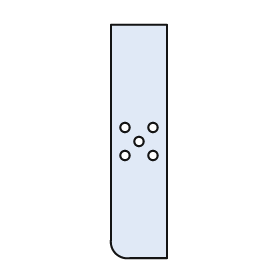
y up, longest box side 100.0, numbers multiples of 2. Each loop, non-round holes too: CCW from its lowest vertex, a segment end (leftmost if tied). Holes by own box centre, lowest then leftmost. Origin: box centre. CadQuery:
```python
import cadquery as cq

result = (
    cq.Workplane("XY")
    .moveTo(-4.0, -50.0)
    .lineTo(12.0, -50.0)
    .lineTo(12.0, 50.0)
    .lineTo(-12.0, 50.0)
    .lineTo(-12.0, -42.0)
    .threePointArc((-10.0, -48.0), (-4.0, -50.0))
    .close()
    .moveTo(-6.0, -6.0)
    .circle(2.0)
    .moveTo(6.0, -6.0)
    .circle(2.0)
    .moveTo(0.0, 0.0)
    .circle(2.0)
    .moveTo(-6.0, 6.0)
    .circle(2.0)
    .moveTo(6.0, 6.0)
    .circle(2.0)
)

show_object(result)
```